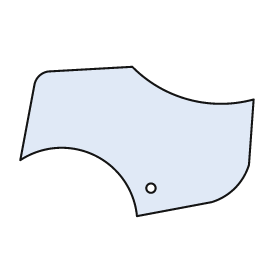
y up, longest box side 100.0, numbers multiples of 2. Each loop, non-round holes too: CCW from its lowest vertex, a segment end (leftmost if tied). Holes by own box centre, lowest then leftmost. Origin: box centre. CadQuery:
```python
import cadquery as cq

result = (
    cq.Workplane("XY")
    .moveTo(0.0, -32.0)
    .lineTo(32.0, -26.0)
    .threePointArc((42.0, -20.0), (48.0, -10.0))
    .lineTo(50.0, 18.0)
    .threePointArc((22.0, 18.0), (-2.0, 32.0))
    .lineTo(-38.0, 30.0)
    .threePointArc((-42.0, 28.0), (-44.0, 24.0))
    .lineTo(-50.0, -8.0)
    .threePointArc((-18.0, -6.0), (0.0, -32.0))
    .close()
    .moveTo(6.0, -20.0)
    .circle(2.0)
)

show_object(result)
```